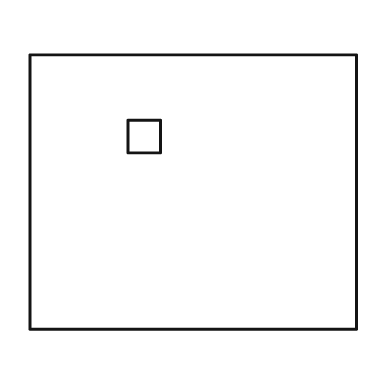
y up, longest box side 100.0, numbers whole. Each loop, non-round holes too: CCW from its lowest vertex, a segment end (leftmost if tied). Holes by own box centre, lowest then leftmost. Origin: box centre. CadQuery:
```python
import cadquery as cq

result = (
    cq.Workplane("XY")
    .moveTo(-50.0, -42.0)
    .lineTo(50.0, -42.0)
    .lineTo(50.0, 42.0)
    .lineTo(-50.0, 42.0)
    .close()
    .moveTo(-20.0, 12.0)
    .lineTo(-10.0, 12.0)
    .lineTo(-10.0, 22.0)
    .lineTo(-20.0, 22.0)
    .close()
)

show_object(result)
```